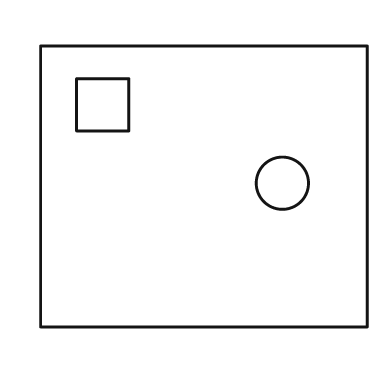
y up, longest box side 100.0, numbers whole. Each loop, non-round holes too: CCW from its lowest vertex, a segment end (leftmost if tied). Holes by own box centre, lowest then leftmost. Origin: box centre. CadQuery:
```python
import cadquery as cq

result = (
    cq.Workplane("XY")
    .moveTo(-50.0, -43.0)
    .lineTo(50.0, -43.0)
    .lineTo(50.0, 43.0)
    .lineTo(-50.0, 43.0)
    .close()
    .moveTo(24.0, 1.0)
    .circle(8.0)
    .moveTo(-39.0, 17.0)
    .lineTo(-23.0, 17.0)
    .lineTo(-23.0, 33.0)
    .lineTo(-39.0, 33.0)
    .close()
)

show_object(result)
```